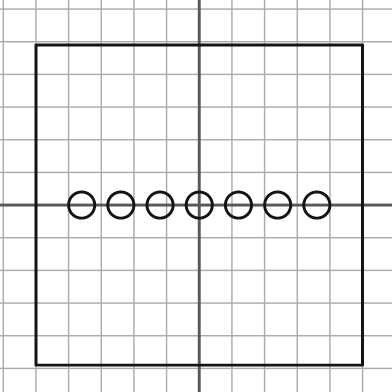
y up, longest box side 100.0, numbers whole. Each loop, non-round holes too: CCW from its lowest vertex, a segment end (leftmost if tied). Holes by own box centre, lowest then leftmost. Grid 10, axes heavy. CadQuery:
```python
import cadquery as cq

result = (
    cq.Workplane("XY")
    .moveTo(-50.0, -49.0)
    .lineTo(50.0, -49.0)
    .lineTo(50.0, 49.0)
    .lineTo(-50.0, 49.0)
    .close()
    .moveTo(-36.0, 0.0)
    .circle(4.0)
    .moveTo(-24.0, 0.0)
    .circle(4.0)
    .moveTo(-12.0, 0.0)
    .circle(4.0)
    .moveTo(0.0, 0.0)
    .circle(4.0)
    .moveTo(12.0, 0.0)
    .circle(4.0)
    .moveTo(24.0, 0.0)
    .circle(4.0)
    .moveTo(36.0, 0.0)
    .circle(4.0)
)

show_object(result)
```